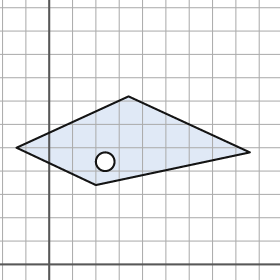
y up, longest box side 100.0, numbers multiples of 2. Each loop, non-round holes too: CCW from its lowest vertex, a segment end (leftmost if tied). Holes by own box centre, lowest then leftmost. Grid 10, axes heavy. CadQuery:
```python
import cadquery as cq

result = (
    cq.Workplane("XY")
    .moveTo(20.0, 34.0)
    .lineTo(86.0, 48.0)
    .lineTo(34.0, 72.0)
    .lineTo(-14.0, 50.0)
    .close()
    .moveTo(24.0, 44.0)
    .circle(4.0)
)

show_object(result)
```